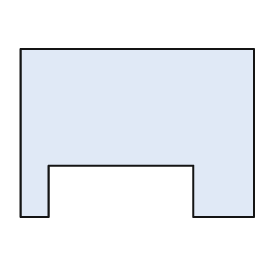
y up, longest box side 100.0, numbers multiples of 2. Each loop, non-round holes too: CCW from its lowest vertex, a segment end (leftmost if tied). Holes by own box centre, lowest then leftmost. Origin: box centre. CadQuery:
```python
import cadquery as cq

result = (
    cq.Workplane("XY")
    .moveTo(-50.0, -36.0)
    .lineTo(-38.0, -36.0)
    .lineTo(-38.0, -14.0)
    .lineTo(24.0, -14.0)
    .lineTo(24.0, -36.0)
    .lineTo(50.0, -36.0)
    .lineTo(50.0, 36.0)
    .lineTo(-50.0, 36.0)
    .close()
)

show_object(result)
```